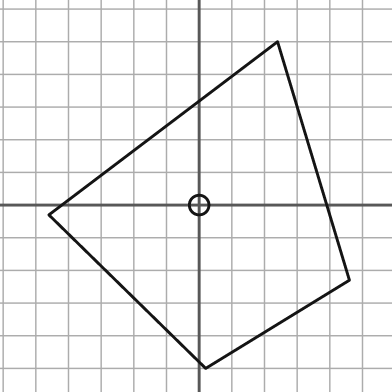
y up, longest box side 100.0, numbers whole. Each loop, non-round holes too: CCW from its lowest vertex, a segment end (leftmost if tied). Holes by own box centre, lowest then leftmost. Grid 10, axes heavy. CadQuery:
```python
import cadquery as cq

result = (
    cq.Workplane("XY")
    .moveTo(2.0, -50.0)
    .lineTo(46.0, -23.0)
    .lineTo(24.0, 50.0)
    .lineTo(-46.0, -3.0)
    .close()
    .moveTo(0.0, 0.0)
    .circle(3.0)
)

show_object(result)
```